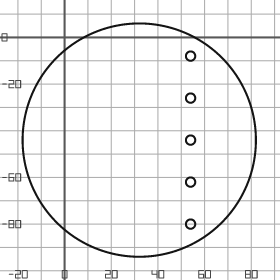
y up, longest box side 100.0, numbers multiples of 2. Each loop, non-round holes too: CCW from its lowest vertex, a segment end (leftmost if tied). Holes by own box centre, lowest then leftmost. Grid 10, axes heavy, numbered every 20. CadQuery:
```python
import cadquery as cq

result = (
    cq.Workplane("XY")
    .moveTo(32.0, -44.0)
    .circle(50.0)
    .moveTo(54.0, -80.0)
    .circle(2.0)
    .moveTo(54.0, -62.0)
    .circle(2.0)
    .moveTo(54.0, -44.0)
    .circle(2.0)
    .moveTo(54.0, -26.0)
    .circle(2.0)
    .moveTo(54.0, -8.0)
    .circle(2.0)
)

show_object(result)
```